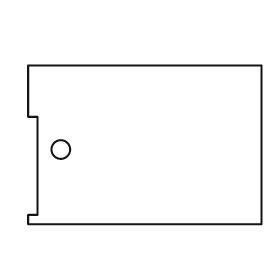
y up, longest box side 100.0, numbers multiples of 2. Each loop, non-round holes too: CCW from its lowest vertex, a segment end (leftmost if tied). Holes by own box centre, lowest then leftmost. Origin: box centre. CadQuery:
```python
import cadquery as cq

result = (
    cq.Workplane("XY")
    .moveTo(-50.0, -34.0)
    .lineTo(50.0, -34.0)
    .lineTo(50.0, 34.0)
    .lineTo(-50.0, 34.0)
    .lineTo(-50.0, 12.0)
    .lineTo(-46.0, 12.0)
    .lineTo(-46.0, -30.0)
    .lineTo(-50.0, -30.0)
    .close()
    .moveTo(-36.0, -2.0)
    .circle(4.0)
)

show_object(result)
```